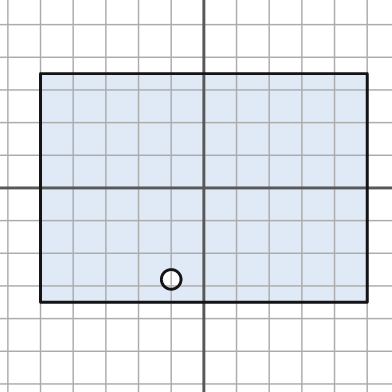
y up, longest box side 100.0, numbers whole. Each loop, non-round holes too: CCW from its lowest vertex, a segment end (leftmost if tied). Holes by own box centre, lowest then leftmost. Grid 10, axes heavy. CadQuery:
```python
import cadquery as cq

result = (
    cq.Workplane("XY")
    .moveTo(-50.0, -35.0)
    .lineTo(50.0, -35.0)
    .lineTo(50.0, 35.0)
    .lineTo(-50.0, 35.0)
    .close()
    .moveTo(-10.0, -28.0)
    .circle(3.0)
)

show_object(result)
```